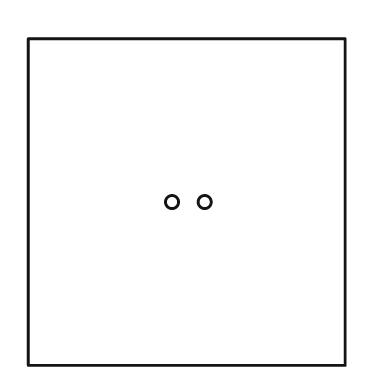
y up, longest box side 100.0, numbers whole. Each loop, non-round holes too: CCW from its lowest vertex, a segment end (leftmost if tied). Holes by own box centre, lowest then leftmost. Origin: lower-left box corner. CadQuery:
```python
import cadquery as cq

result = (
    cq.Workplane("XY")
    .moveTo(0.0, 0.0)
    .lineTo(97.0, 0.0)
    .lineTo(97.0, 100.0)
    .lineTo(0.0, 100.0)
    .close()
    .moveTo(44.0, 50.0)
    .circle(2.0)
    .moveTo(54.0, 50.0)
    .circle(2.0)
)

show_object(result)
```